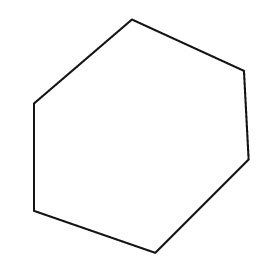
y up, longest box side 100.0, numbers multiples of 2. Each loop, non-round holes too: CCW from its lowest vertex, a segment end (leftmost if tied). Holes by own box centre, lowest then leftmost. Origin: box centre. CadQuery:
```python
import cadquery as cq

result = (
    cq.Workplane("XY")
    .moveTo(6.0, -50.0)
    .lineTo(46.0, -10.0)
    .lineTo(44.0, 28.0)
    .lineTo(-4.0, 50.0)
    .lineTo(-46.0, 14.0)
    .lineTo(-46.0, -32.0)
    .close()
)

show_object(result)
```